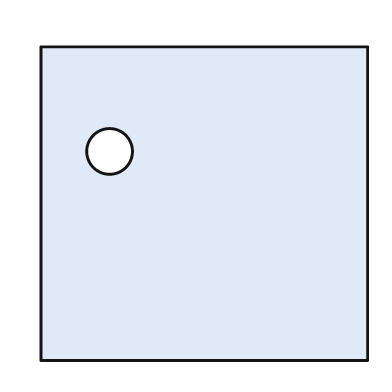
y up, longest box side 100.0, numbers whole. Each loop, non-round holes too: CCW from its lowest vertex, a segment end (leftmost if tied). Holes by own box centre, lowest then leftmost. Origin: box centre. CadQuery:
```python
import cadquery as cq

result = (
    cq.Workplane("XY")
    .moveTo(-50.0, -48.0)
    .lineTo(50.0, -48.0)
    .lineTo(50.0, 48.0)
    .lineTo(-50.0, 48.0)
    .close()
    .moveTo(-29.0, 16.0)
    .circle(7.0)
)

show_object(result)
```